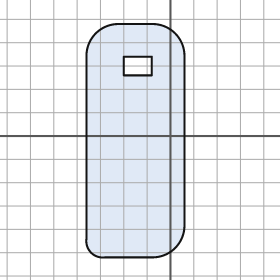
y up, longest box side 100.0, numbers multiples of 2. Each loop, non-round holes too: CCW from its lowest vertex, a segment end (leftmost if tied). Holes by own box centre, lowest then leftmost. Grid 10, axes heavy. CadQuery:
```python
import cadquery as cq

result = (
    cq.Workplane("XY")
    .moveTo(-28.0, -52.0)
    .lineTo(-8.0, -52.0)
    .threePointArc((2.0, -48.0), (6.0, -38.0))
    .lineTo(6.0, 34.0)
    .threePointArc((2.0, 44.0), (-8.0, 48.0))
    .lineTo(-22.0, 48.0)
    .threePointArc((-32.0, 44.0), (-36.0, 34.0))
    .lineTo(-36.0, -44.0)
    .threePointArc((-34.0, -50.0), (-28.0, -52.0))
    .close()
    .moveTo(-20.0, 26.0)
    .lineTo(-8.0, 26.0)
    .lineTo(-8.0, 34.0)
    .lineTo(-20.0, 34.0)
    .close()
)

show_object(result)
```